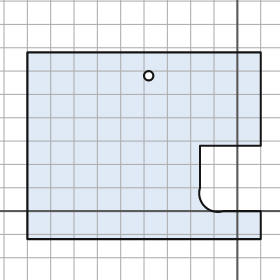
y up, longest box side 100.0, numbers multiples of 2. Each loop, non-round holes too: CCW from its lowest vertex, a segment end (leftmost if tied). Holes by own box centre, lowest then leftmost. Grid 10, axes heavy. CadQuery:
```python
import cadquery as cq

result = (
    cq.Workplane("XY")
    .moveTo(-90.0, -12.0)
    .lineTo(10.0, -12.0)
    .lineTo(10.0, 0.0)
    .lineTo(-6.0, 0.0)
    .threePointArc((-14.0, 2.0), (-16.0, 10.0))
    .lineTo(-16.0, 28.0)
    .lineTo(10.0, 28.0)
    .lineTo(10.0, 68.0)
    .lineTo(-90.0, 68.0)
    .close()
    .moveTo(-38.0, 58.0)
    .circle(2.0)
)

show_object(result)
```